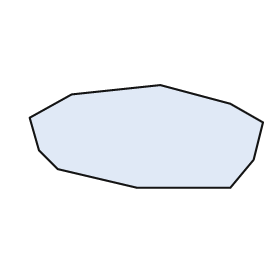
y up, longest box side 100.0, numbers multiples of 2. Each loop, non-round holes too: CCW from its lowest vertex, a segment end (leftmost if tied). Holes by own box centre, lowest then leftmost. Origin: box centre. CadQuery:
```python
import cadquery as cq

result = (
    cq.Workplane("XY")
    .moveTo(-4.0, -22.0)
    .lineTo(36.0, -22.0)
    .lineTo(46.0, -10.0)
    .lineTo(50.0, 6.0)
    .lineTo(36.0, 14.0)
    .lineTo(6.0, 22.0)
    .lineTo(-32.0, 18.0)
    .lineTo(-50.0, 8.0)
    .lineTo(-46.0, -6.0)
    .lineTo(-38.0, -14.0)
    .close()
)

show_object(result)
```